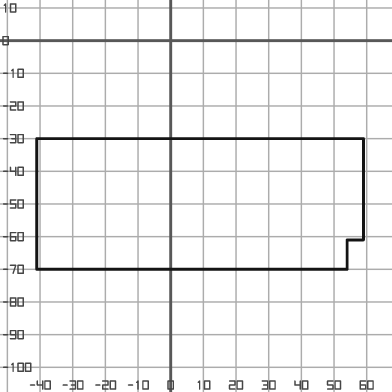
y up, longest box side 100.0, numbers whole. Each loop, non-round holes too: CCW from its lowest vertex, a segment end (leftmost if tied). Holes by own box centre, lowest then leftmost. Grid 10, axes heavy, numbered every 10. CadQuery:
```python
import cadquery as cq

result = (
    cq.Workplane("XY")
    .moveTo(-41.0, -70.0)
    .lineTo(54.0, -70.0)
    .lineTo(54.0, -61.0)
    .lineTo(59.0, -61.0)
    .lineTo(59.0, -30.0)
    .lineTo(-41.0, -30.0)
    .close()
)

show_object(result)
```